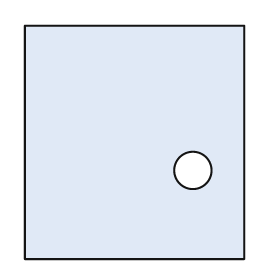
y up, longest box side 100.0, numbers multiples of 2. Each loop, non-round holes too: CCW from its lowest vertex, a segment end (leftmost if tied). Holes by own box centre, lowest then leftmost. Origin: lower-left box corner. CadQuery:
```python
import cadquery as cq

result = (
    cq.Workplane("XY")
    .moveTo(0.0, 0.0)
    .lineTo(94.0, 0.0)
    .lineTo(94.0, 100.0)
    .lineTo(0.0, 100.0)
    .close()
    .moveTo(72.0, 38.0)
    .circle(8.0)
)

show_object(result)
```